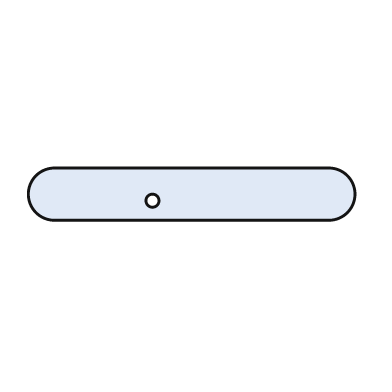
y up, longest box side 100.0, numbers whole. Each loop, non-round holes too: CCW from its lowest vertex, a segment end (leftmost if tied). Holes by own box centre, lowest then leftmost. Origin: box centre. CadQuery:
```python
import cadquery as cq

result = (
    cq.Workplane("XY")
    .moveTo(-42.0, -8.0)
    .lineTo(42.0, -8.0)
    .threePointArc((50.0, 0.0), (42.0, 8.0))
    .lineTo(-42.0, 8.0)
    .threePointArc((-50.0, 0.0), (-42.0, -8.0))
    .close()
    .moveTo(-12.0, -2.0)
    .circle(2.0)
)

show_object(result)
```